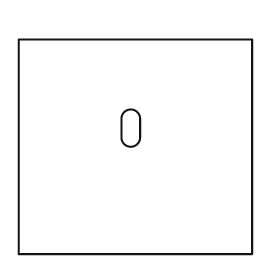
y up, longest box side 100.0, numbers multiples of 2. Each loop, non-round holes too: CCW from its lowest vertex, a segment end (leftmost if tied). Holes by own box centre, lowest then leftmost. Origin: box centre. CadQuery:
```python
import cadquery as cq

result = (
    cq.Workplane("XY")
    .moveTo(-50.0, -46.0)
    .lineTo(50.0, -46.0)
    .lineTo(50.0, 46.0)
    .lineTo(-50.0, 46.0)
    .close()
    .moveTo(-6.0, 4.0)
    .threePointArc((-2.0, 0.0), (2.0, 4.0))
    .lineTo(2.0, 12.0)
    .threePointArc((-2.0, 16.0), (-6.0, 12.0))
    .close()
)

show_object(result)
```